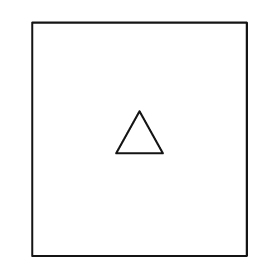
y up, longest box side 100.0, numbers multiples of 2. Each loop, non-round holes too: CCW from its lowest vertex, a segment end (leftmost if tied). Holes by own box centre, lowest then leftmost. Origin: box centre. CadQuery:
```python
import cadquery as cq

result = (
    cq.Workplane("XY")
    .moveTo(-46.0, -50.0)
    .lineTo(46.0, -50.0)
    .lineTo(46.0, 50.0)
    .lineTo(-46.0, 50.0)
    .close()
    .moveTo(-10.0, -6.0)
    .lineTo(10.0, -6.0)
    .lineTo(0.0, 12.0)
    .close()
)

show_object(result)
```